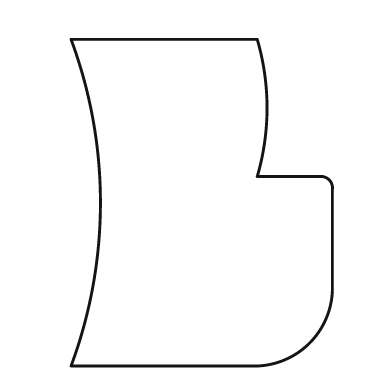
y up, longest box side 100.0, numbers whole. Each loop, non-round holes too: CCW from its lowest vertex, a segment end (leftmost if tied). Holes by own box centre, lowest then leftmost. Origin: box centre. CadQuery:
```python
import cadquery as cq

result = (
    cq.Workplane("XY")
    .moveTo(-40.0, -50.0)
    .lineTo(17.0, -50.0)
    .threePointArc((33.0, -43.0), (40.0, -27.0))
    .lineTo(40.0, 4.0)
    .threePointArc((39.0, 7.0), (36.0, 8.0))
    .lineTo(17.0, 8.0)
    .threePointArc((20.0, 29.0), (17.0, 50.0))
    .lineTo(-40.0, 50.0)
    .threePointArc((-31.0, 0.0), (-40.0, -50.0))
    .close()
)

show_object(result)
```